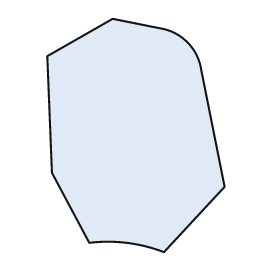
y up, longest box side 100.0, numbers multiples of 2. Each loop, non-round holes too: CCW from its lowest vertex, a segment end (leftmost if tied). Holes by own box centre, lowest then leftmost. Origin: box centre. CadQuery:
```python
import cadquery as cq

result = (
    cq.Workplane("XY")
    .moveTo(12.0, -50.0)
    .lineTo(38.0, -22.0)
    .lineTo(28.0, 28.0)
    .threePointArc((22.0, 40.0), (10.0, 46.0))
    .lineTo(-10.0, 50.0)
    .lineTo(-38.0, 34.0)
    .lineTo(-36.0, -16.0)
    .lineTo(-20.0, -46.0)
    .threePointArc((-4.0, -46.0), (12.0, -50.0))
    .close()
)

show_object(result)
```